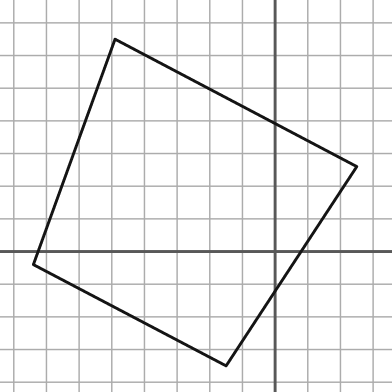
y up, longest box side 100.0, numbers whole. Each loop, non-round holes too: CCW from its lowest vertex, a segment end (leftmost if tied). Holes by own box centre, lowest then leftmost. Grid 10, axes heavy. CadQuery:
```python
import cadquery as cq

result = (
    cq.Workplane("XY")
    .moveTo(-15.0, -35.0)
    .lineTo(25.0, 26.0)
    .lineTo(-49.0, 65.0)
    .lineTo(-74.0, -4.0)
    .close()
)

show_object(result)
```